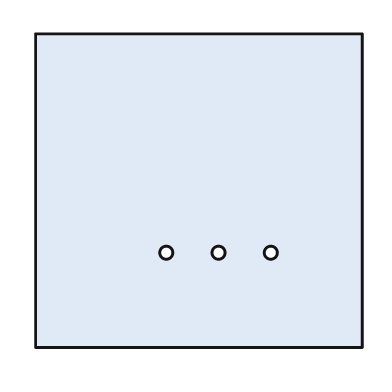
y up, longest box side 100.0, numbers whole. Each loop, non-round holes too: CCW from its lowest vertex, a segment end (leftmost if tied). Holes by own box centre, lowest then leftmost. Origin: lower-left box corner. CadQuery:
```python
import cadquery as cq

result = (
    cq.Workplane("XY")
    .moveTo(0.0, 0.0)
    .lineTo(100.0, 0.0)
    .lineTo(100.0, 96.0)
    .lineTo(0.0, 96.0)
    .close()
    .moveTo(40.0, 29.0)
    .circle(2.0)
    .moveTo(56.0, 29.0)
    .circle(2.0)
    .moveTo(72.0, 29.0)
    .circle(2.0)
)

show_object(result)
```